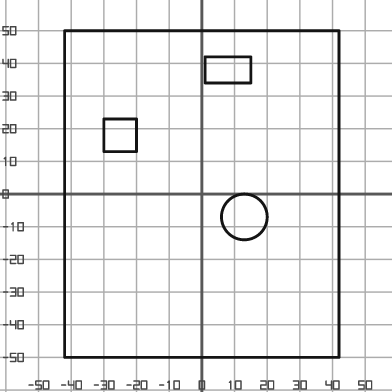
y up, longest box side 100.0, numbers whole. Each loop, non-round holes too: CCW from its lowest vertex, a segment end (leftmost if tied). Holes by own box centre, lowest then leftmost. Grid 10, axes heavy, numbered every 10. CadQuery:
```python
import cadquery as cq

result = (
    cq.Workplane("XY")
    .moveTo(-42.0, -50.0)
    .lineTo(42.0, -50.0)
    .lineTo(42.0, 50.0)
    .lineTo(-42.0, 50.0)
    .close()
    .moveTo(13.0, -7.0)
    .circle(7.0)
    .moveTo(-30.0, 13.0)
    .lineTo(-20.0, 13.0)
    .lineTo(-20.0, 23.0)
    .lineTo(-30.0, 23.0)
    .close()
    .moveTo(1.0, 34.0)
    .lineTo(15.0, 34.0)
    .lineTo(15.0, 42.0)
    .lineTo(1.0, 42.0)
    .close()
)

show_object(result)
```